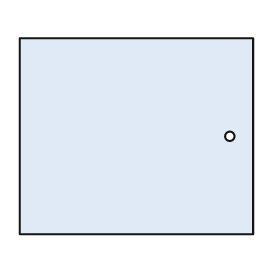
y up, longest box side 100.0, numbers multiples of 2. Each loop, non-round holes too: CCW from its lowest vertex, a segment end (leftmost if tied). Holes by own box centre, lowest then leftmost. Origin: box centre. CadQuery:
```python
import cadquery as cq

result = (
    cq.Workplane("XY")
    .moveTo(-50.0, -42.0)
    .lineTo(50.0, -42.0)
    .lineTo(50.0, 42.0)
    .lineTo(-50.0, 42.0)
    .close()
    .moveTo(40.0, 0.0)
    .circle(2.0)
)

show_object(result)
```